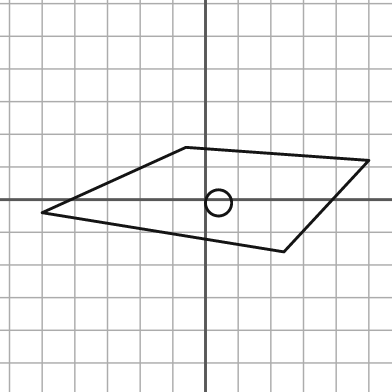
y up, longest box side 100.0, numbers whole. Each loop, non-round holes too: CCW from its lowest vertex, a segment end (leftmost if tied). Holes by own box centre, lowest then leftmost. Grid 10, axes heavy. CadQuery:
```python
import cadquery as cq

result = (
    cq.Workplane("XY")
    .moveTo(24.0, -16.0)
    .lineTo(50.0, 12.0)
    .lineTo(-6.0, 16.0)
    .lineTo(-50.0, -4.0)
    .close()
    .moveTo(4.0, -1.0)
    .circle(4.0)
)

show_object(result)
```